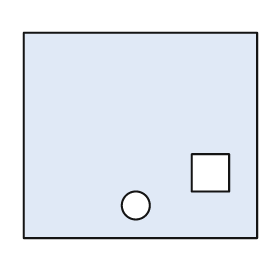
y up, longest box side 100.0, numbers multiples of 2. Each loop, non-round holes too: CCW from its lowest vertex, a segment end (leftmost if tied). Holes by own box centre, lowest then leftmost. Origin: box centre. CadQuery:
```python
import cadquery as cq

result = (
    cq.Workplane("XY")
    .moveTo(-50.0, -44.0)
    .lineTo(50.0, -44.0)
    .lineTo(50.0, 44.0)
    .lineTo(-50.0, 44.0)
    .close()
    .moveTo(-2.0, -30.0)
    .circle(6.0)
    .moveTo(22.0, -24.0)
    .lineTo(38.0, -24.0)
    .lineTo(38.0, -8.0)
    .lineTo(22.0, -8.0)
    .close()
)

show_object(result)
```